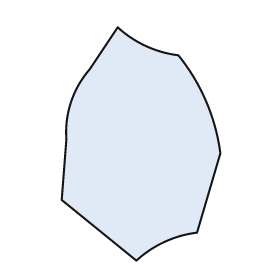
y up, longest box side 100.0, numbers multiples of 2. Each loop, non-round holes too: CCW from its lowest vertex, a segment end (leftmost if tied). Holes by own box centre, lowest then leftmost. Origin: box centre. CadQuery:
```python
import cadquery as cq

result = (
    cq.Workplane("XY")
    .moveTo(-2.0, -50.0)
    .threePointArc((10.0, -42.0), (24.0, -38.0))
    .lineTo(34.0, -4.0)
    .threePointArc((28.0, 18.0), (16.0, 38.0))
    .threePointArc((2.0, 42.0), (-10.0, 50.0))
    .lineTo(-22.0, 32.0)
    .threePointArc((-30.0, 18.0), (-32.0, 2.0))
    .lineTo(-34.0, -24.0)
    .close()
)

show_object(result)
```